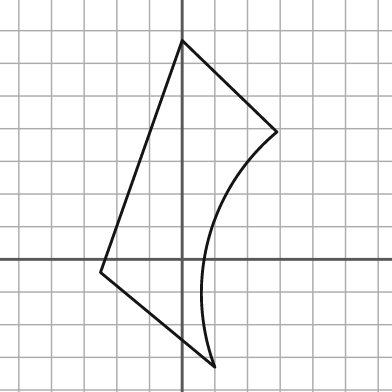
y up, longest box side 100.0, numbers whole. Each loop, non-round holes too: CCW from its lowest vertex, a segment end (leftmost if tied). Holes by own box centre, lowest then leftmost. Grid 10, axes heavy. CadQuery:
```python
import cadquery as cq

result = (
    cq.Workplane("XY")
    .moveTo(10.0, -33.0)
    .threePointArc((8.0, 6.0), (29.0, 39.0))
    .lineTo(0.0, 67.0)
    .lineTo(-25.0, -4.0)
    .close()
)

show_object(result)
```